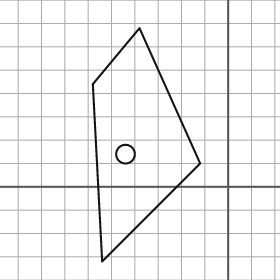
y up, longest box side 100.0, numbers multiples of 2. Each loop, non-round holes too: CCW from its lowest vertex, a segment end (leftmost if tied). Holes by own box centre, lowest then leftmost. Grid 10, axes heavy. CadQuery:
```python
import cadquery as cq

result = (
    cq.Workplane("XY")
    .moveTo(-54.0, -32.0)
    .lineTo(-12.0, 10.0)
    .lineTo(-38.0, 68.0)
    .lineTo(-58.0, 44.0)
    .close()
    .moveTo(-44.0, 14.0)
    .circle(4.0)
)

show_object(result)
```